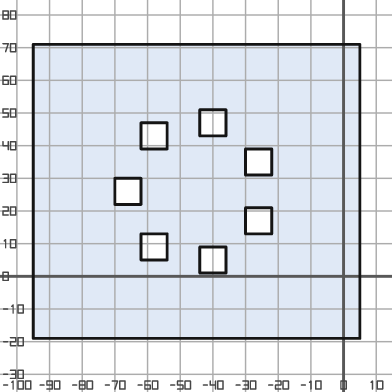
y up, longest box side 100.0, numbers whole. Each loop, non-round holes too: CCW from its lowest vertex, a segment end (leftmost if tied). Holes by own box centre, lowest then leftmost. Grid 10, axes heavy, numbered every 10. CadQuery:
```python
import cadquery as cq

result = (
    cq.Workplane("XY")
    .moveTo(-95.0, -19.0)
    .lineTo(5.0, -19.0)
    .lineTo(5.0, 71.0)
    .lineTo(-95.0, 71.0)
    .close()
    .moveTo(-44.0, 1.0)
    .lineTo(-36.0, 1.0)
    .lineTo(-36.0, 9.0)
    .lineTo(-44.0, 9.0)
    .close()
    .moveTo(-62.0, 5.0)
    .lineTo(-54.0, 5.0)
    .lineTo(-54.0, 13.0)
    .lineTo(-62.0, 13.0)
    .close()
    .moveTo(-30.0, 13.0)
    .lineTo(-22.0, 13.0)
    .lineTo(-22.0, 21.0)
    .lineTo(-30.0, 21.0)
    .close()
    .moveTo(-70.0, 22.0)
    .lineTo(-62.0, 22.0)
    .lineTo(-62.0, 30.0)
    .lineTo(-70.0, 30.0)
    .close()
    .moveTo(-30.0, 31.0)
    .lineTo(-22.0, 31.0)
    .lineTo(-22.0, 39.0)
    .lineTo(-30.0, 39.0)
    .close()
    .moveTo(-62.0, 39.0)
    .lineTo(-54.0, 39.0)
    .lineTo(-54.0, 47.0)
    .lineTo(-62.0, 47.0)
    .close()
    .moveTo(-44.0, 43.0)
    .lineTo(-36.0, 43.0)
    .lineTo(-36.0, 51.0)
    .lineTo(-44.0, 51.0)
    .close()
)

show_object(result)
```